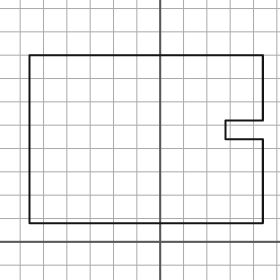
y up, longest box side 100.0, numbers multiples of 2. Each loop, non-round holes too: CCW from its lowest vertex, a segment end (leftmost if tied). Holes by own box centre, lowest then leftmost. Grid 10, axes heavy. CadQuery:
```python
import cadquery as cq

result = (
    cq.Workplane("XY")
    .moveTo(-56.0, 8.0)
    .lineTo(44.0, 8.0)
    .lineTo(44.0, 44.0)
    .lineTo(28.0, 44.0)
    .lineTo(28.0, 52.0)
    .lineTo(44.0, 52.0)
    .lineTo(44.0, 80.0)
    .lineTo(-56.0, 80.0)
    .close()
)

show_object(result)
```